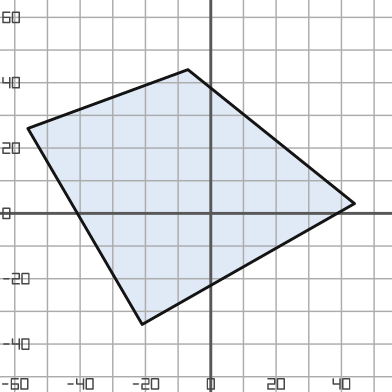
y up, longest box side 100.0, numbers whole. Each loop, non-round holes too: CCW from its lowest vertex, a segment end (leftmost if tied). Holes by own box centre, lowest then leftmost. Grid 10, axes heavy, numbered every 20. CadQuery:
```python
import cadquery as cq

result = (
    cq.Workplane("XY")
    .moveTo(-21.0, -34.0)
    .lineTo(44.0, 3.0)
    .lineTo(-7.0, 44.0)
    .lineTo(-56.0, 26.0)
    .close()
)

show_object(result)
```